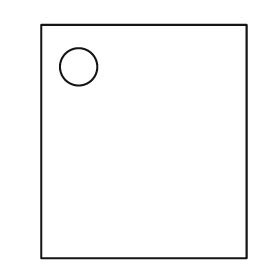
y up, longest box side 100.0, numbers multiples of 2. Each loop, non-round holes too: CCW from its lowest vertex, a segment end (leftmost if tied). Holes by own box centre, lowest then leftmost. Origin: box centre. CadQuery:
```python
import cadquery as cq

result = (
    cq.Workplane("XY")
    .moveTo(-44.0, -50.0)
    .lineTo(44.0, -50.0)
    .lineTo(44.0, 50.0)
    .lineTo(-44.0, 50.0)
    .close()
    .moveTo(-28.0, 32.0)
    .circle(8.0)
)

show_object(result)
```